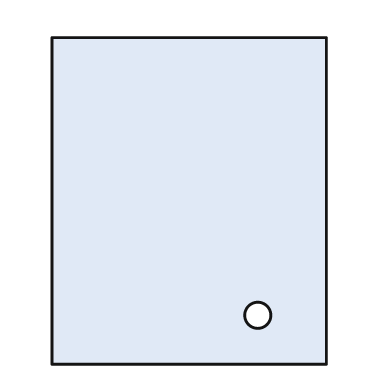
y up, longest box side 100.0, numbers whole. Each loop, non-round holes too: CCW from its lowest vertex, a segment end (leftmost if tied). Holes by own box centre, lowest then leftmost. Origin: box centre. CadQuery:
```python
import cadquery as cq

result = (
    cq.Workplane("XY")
    .moveTo(-42.0, -50.0)
    .lineTo(42.0, -50.0)
    .lineTo(42.0, 50.0)
    .lineTo(-42.0, 50.0)
    .close()
    .moveTo(21.0, -35.0)
    .circle(4.0)
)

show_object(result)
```